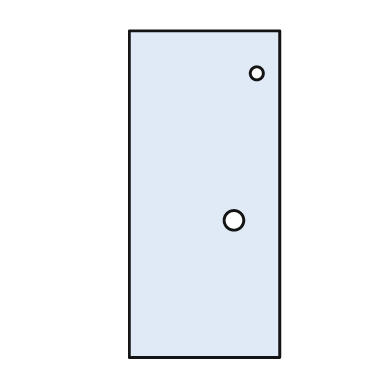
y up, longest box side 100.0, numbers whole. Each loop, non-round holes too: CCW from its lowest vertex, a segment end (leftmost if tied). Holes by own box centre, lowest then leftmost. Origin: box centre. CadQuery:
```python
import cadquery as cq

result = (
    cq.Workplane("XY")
    .moveTo(-23.0, -50.0)
    .lineTo(23.0, -50.0)
    .lineTo(23.0, 50.0)
    .lineTo(-23.0, 50.0)
    .close()
    .moveTo(9.0, -8.0)
    .circle(3.0)
    .moveTo(16.0, 37.0)
    .circle(2.0)
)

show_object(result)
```